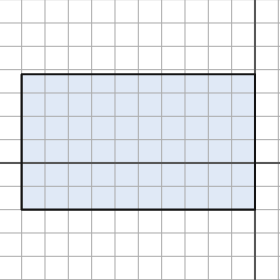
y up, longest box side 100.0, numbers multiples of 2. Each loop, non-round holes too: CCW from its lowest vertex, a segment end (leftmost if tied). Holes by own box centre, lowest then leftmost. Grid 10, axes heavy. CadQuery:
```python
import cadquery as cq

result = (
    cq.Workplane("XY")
    .moveTo(-100.0, -20.0)
    .lineTo(0.0, -20.0)
    .lineTo(0.0, 38.0)
    .lineTo(-100.0, 38.0)
    .close()
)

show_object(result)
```